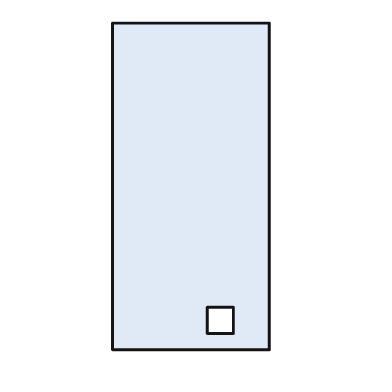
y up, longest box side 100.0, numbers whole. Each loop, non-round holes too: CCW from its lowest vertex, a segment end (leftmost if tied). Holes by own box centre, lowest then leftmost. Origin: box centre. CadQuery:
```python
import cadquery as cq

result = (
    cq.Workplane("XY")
    .moveTo(-24.0, -50.0)
    .lineTo(24.0, -50.0)
    .lineTo(24.0, 50.0)
    .lineTo(-24.0, 50.0)
    .close()
    .moveTo(5.0, -45.0)
    .lineTo(13.0, -45.0)
    .lineTo(13.0, -37.0)
    .lineTo(5.0, -37.0)
    .close()
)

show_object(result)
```